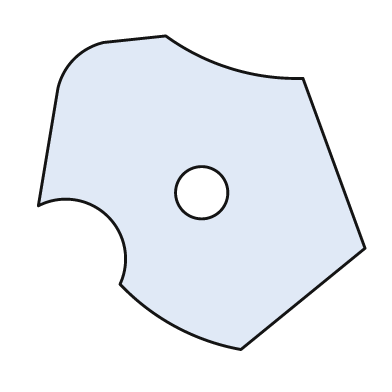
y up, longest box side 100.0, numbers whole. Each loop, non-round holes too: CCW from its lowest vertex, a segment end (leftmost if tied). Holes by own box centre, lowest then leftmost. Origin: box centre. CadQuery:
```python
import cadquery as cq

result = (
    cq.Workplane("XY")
    .moveTo(12.0, -48.0)
    .lineTo(50.0, -17.0)
    .lineTo(31.0, 35.0)
    .threePointArc((9.0, 38.0), (-11.0, 48.0))
    .lineTo(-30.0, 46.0)
    .threePointArc((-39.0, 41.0), (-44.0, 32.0))
    .lineTo(-50.0, -4.0)
    .threePointArc((-29.0, -7.0), (-25.0, -28.0))
    .threePointArc((-8.0, -41.0), (12.0, -48.0))
    .close()
    .moveTo(0.0, 0.0)
    .circle(8.0)
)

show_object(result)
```